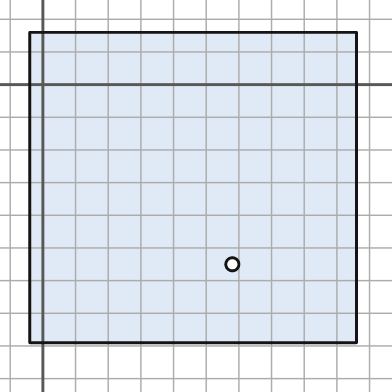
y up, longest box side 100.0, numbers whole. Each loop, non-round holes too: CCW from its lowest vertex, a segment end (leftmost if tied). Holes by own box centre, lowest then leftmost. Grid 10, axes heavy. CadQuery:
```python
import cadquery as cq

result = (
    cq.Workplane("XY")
    .moveTo(-4.0, -79.0)
    .lineTo(96.0, -79.0)
    .lineTo(96.0, 16.0)
    .lineTo(-4.0, 16.0)
    .close()
    .moveTo(58.0, -55.0)
    .circle(2.0)
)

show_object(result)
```